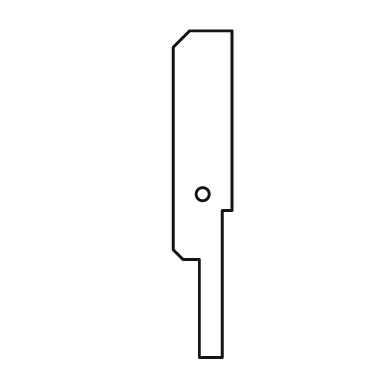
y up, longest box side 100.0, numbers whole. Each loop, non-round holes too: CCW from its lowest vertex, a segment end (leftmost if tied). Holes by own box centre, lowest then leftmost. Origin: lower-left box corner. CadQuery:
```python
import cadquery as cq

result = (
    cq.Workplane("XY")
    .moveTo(8.0, 0.0)
    .lineTo(15.0, 0.0)
    .lineTo(15.0, 45.0)
    .lineTo(18.0, 45.0)
    .lineTo(18.0, 100.0)
    .lineTo(5.0, 100.0)
    .lineTo(0.0, 95.0)
    .lineTo(0.0, 33.0)
    .lineTo(3.0, 30.0)
    .lineTo(8.0, 30.0)
    .close()
    .moveTo(9.0, 50.0)
    .circle(2.0)
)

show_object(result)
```